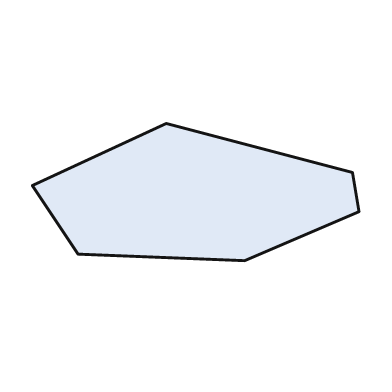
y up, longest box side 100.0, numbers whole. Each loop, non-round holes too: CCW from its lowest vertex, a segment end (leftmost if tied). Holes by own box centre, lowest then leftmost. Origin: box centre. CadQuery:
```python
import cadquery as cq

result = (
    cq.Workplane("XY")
    .moveTo(15.0, -21.0)
    .lineTo(50.0, -6.0)
    .lineTo(48.0, 6.0)
    .lineTo(-9.0, 21.0)
    .lineTo(-50.0, 2.0)
    .lineTo(-36.0, -19.0)
    .close()
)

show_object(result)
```